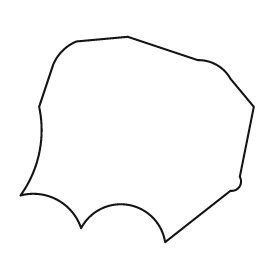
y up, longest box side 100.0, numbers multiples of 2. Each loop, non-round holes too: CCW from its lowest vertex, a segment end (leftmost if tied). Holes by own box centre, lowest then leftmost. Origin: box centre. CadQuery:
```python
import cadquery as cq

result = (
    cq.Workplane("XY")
    .moveTo(12.0, -44.0)
    .lineTo(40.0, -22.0)
    .threePointArc((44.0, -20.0), (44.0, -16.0))
    .lineTo(50.0, 14.0)
    .lineTo(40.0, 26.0)
    .threePointArc((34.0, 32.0), (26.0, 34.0))
    .lineTo(-4.0, 44.0)
    .lineTo(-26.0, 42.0)
    .threePointArc((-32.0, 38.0), (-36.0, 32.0))
    .lineTo(-42.0, 14.0)
    .threePointArc((-42.0, -6.0), (-50.0, -24.0))
    .threePointArc((-34.0, -26.0), (-24.0, -38.0))
    .threePointArc((-4.0, -28.0), (12.0, -44.0))
    .close()
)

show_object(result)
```